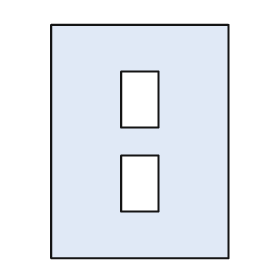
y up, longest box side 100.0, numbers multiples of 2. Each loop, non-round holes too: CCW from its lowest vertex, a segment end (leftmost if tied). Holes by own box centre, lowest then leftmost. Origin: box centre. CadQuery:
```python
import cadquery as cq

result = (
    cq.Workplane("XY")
    .moveTo(-38.0, -50.0)
    .lineTo(38.0, -50.0)
    .lineTo(38.0, 50.0)
    .lineTo(-38.0, 50.0)
    .close()
    .moveTo(-8.0, -30.0)
    .lineTo(8.0, -30.0)
    .lineTo(8.0, -6.0)
    .lineTo(-8.0, -6.0)
    .close()
    .moveTo(-8.0, 6.0)
    .lineTo(8.0, 6.0)
    .lineTo(8.0, 30.0)
    .lineTo(-8.0, 30.0)
    .close()
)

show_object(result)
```